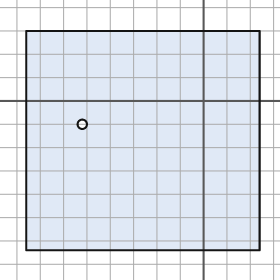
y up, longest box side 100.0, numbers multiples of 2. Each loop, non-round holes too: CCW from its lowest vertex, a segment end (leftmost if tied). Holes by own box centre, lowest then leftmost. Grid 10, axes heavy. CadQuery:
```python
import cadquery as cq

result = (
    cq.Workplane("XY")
    .moveTo(-76.0, -64.0)
    .lineTo(24.0, -64.0)
    .lineTo(24.0, 30.0)
    .lineTo(-76.0, 30.0)
    .close()
    .moveTo(-52.0, -10.0)
    .circle(2.0)
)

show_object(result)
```